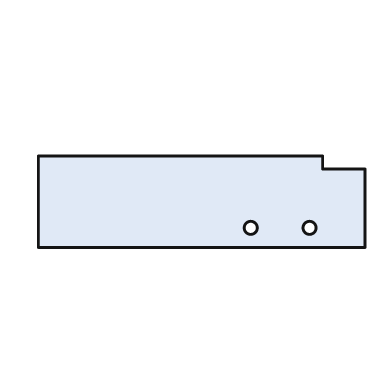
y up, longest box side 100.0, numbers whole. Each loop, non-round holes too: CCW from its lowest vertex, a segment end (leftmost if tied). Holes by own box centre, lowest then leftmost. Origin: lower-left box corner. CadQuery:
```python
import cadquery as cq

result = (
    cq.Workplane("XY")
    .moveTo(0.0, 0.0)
    .lineTo(100.0, 0.0)
    .lineTo(100.0, 24.0)
    .lineTo(87.0, 24.0)
    .lineTo(87.0, 28.0)
    .lineTo(0.0, 28.0)
    .close()
    .moveTo(65.0, 6.0)
    .circle(2.0)
    .moveTo(83.0, 6.0)
    .circle(2.0)
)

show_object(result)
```